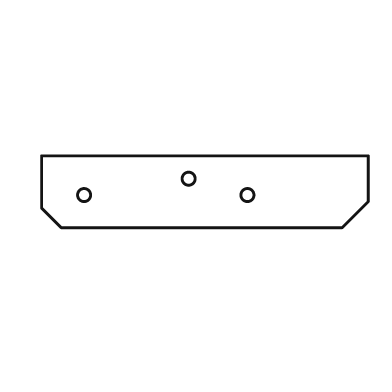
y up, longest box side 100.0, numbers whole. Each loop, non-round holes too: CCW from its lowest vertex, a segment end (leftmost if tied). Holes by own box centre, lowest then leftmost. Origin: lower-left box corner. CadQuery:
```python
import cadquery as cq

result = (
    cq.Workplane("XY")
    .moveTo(6.0, 0.0)
    .lineTo(92.0, 0.0)
    .lineTo(100.0, 8.0)
    .lineTo(100.0, 22.0)
    .lineTo(0.0, 22.0)
    .lineTo(0.0, 6.0)
    .close()
    .moveTo(13.0, 10.0)
    .circle(2.0)
    .moveTo(63.0, 10.0)
    .circle(2.0)
    .moveTo(45.0, 15.0)
    .circle(2.0)
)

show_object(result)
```